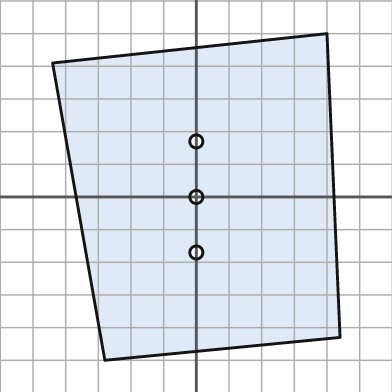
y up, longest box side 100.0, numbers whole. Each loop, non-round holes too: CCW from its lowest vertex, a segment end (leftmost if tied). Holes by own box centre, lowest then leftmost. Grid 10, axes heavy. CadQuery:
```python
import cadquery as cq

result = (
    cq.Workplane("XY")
    .moveTo(-28.0, -50.0)
    .lineTo(44.0, -43.0)
    .lineTo(40.0, 50.0)
    .lineTo(-44.0, 41.0)
    .close()
    .moveTo(0.0, -17.0)
    .circle(2.0)
    .moveTo(0.0, 0.0)
    .circle(2.0)
    .moveTo(0.0, 17.0)
    .circle(2.0)
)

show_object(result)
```